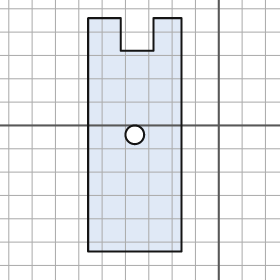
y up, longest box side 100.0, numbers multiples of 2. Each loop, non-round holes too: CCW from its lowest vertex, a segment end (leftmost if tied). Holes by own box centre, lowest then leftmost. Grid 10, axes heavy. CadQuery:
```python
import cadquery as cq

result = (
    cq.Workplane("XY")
    .moveTo(-56.0, -54.0)
    .lineTo(-16.0, -54.0)
    .lineTo(-16.0, 46.0)
    .lineTo(-28.0, 46.0)
    .lineTo(-28.0, 32.0)
    .lineTo(-42.0, 32.0)
    .lineTo(-42.0, 46.0)
    .lineTo(-56.0, 46.0)
    .close()
    .moveTo(-36.0, -4.0)
    .circle(4.0)
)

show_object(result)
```